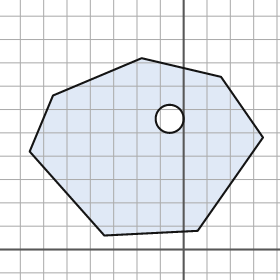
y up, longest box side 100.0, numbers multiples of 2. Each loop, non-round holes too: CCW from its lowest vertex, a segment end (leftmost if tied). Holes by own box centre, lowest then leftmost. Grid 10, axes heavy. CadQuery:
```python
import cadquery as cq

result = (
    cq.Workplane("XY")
    .moveTo(-34.0, 6.0)
    .lineTo(6.0, 8.0)
    .lineTo(34.0, 48.0)
    .lineTo(16.0, 74.0)
    .lineTo(-18.0, 82.0)
    .lineTo(-56.0, 66.0)
    .lineTo(-66.0, 42.0)
    .close()
    .moveTo(-6.0, 56.0)
    .circle(6.0)
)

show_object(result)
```